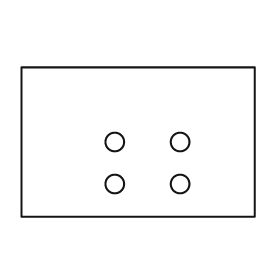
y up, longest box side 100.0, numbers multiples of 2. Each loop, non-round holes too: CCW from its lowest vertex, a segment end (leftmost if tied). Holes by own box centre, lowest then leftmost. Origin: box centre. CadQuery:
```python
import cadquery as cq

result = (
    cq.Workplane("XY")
    .moveTo(-50.0, -32.0)
    .lineTo(50.0, -32.0)
    .lineTo(50.0, 32.0)
    .lineTo(-50.0, 32.0)
    .close()
    .moveTo(-10.0, -18.0)
    .circle(4.0)
    .moveTo(18.0, -18.0)
    .circle(4.0)
    .moveTo(-10.0, 0.0)
    .circle(4.0)
    .moveTo(18.0, 0.0)
    .circle(4.0)
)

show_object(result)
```